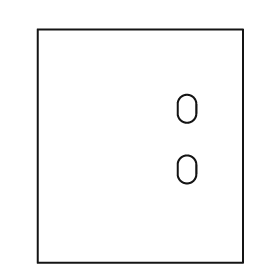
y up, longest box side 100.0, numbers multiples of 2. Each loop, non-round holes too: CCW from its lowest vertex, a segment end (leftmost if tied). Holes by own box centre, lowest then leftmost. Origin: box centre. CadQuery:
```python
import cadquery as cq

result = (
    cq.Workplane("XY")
    .moveTo(-44.0, -50.0)
    .lineTo(44.0, -50.0)
    .lineTo(44.0, 50.0)
    .lineTo(-44.0, 50.0)
    .close()
    .moveTo(16.0, -12.0)
    .threePointArc((20.0, -16.0), (24.0, -12.0))
    .lineTo(24.0, -8.0)
    .threePointArc((20.0, -4.0), (16.0, -8.0))
    .close()
    .moveTo(16.0, 14.0)
    .threePointArc((20.0, 10.0), (24.0, 14.0))
    .lineTo(24.0, 18.0)
    .threePointArc((20.0, 22.0), (16.0, 18.0))
    .close()
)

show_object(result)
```